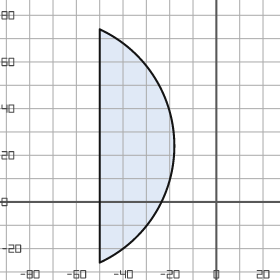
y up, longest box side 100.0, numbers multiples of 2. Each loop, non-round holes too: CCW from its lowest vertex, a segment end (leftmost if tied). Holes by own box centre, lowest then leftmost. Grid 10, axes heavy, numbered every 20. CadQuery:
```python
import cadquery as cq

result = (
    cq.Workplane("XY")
    .moveTo(-50.0, -26.0)
    .threePointArc((-18.0, 24.0), (-50.0, 74.0))
    .close()
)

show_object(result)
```